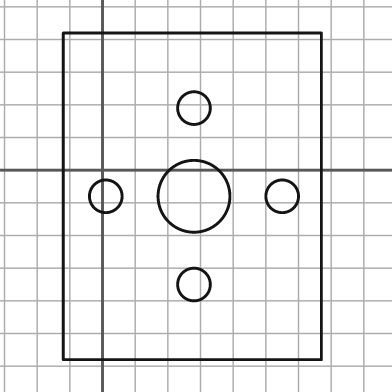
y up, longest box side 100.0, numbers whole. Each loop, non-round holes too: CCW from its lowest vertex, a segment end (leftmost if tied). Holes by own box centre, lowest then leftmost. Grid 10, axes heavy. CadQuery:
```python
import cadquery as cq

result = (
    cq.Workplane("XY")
    .moveTo(-12.0, -58.0)
    .lineTo(67.0, -58.0)
    .lineTo(67.0, 42.0)
    .lineTo(-12.0, 42.0)
    .close()
    .moveTo(28.0, -35.0)
    .circle(5.0)
    .moveTo(1.0, -8.0)
    .circle(5.0)
    .moveTo(28.0, -8.0)
    .circle(11.0)
    .moveTo(55.0, -8.0)
    .circle(5.0)
    .moveTo(28.0, 19.0)
    .circle(5.0)
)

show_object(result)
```